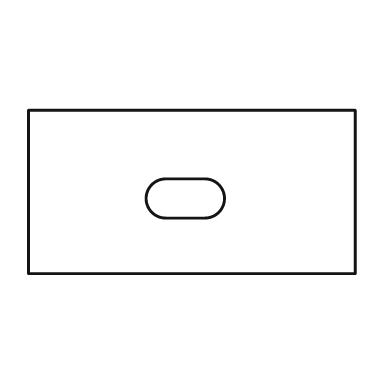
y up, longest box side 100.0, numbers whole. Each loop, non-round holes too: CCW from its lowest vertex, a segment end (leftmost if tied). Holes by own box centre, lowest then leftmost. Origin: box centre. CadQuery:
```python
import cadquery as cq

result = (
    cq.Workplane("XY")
    .moveTo(-50.0, -25.0)
    .lineTo(50.0, -25.0)
    .lineTo(50.0, 25.0)
    .lineTo(-50.0, 25.0)
    .close()
    .moveTo(-8.0, -8.0)
    .lineTo(4.0, -8.0)
    .threePointArc((10.0, -2.0), (4.0, 4.0))
    .lineTo(-8.0, 4.0)
    .threePointArc((-14.0, -2.0), (-8.0, -8.0))
    .close()
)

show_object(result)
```